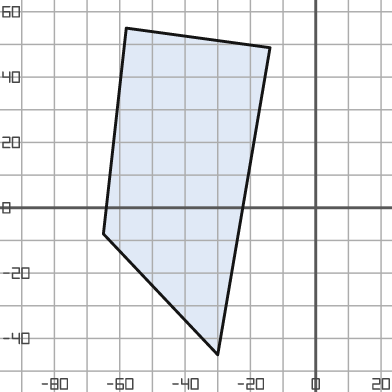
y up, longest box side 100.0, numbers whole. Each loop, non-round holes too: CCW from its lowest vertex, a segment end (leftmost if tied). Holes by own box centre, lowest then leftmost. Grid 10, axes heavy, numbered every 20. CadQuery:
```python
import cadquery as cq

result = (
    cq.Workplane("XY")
    .moveTo(-30.0, -45.0)
    .lineTo(-14.0, 49.0)
    .lineTo(-58.0, 55.0)
    .lineTo(-65.0, -8.0)
    .close()
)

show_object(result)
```